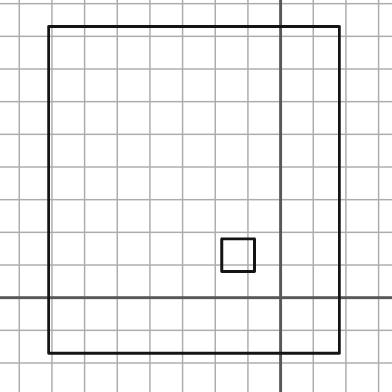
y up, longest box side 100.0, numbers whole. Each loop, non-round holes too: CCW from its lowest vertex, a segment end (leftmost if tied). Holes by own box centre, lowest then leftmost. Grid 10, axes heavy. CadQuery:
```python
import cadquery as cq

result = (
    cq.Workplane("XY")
    .moveTo(-71.0, -17.0)
    .lineTo(18.0, -17.0)
    .lineTo(18.0, 83.0)
    .lineTo(-71.0, 83.0)
    .close()
    .moveTo(-18.0, 8.0)
    .lineTo(-8.0, 8.0)
    .lineTo(-8.0, 18.0)
    .lineTo(-18.0, 18.0)
    .close()
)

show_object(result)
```